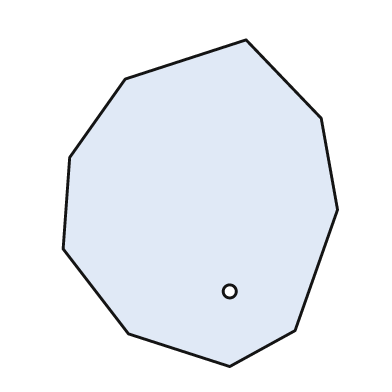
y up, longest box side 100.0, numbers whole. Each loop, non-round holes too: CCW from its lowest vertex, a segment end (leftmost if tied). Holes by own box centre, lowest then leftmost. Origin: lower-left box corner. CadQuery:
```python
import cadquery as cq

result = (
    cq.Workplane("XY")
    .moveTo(51.0, 0.0)
    .lineTo(71.0, 11.0)
    .lineTo(84.0, 48.0)
    .lineTo(79.0, 76.0)
    .lineTo(56.0, 100.0)
    .lineTo(19.0, 88.0)
    .lineTo(2.0, 64.0)
    .lineTo(0.0, 36.0)
    .lineTo(20.0, 10.0)
    .close()
    .moveTo(51.0, 23.0)
    .circle(2.0)
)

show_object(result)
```